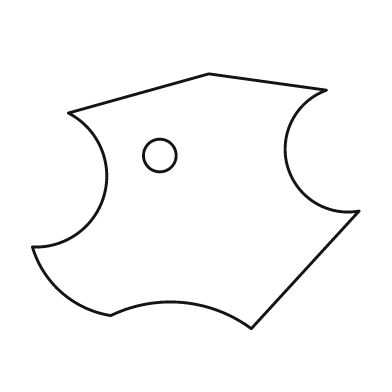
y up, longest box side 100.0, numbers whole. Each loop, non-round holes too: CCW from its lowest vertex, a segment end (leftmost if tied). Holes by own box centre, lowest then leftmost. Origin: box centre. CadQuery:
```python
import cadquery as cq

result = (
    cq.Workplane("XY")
    .moveTo(17.0, -39.0)
    .lineTo(50.0, -3.0)
    .threePointArc((28.0, 11.0), (40.0, 34.0))
    .lineTo(4.0, 39.0)
    .lineTo(-39.0, 27.0)
    .threePointArc((-28.0, 2.0), (-50.0, -14.0))
    .threePointArc((-41.0, -28.0), (-26.0, -35.0))
    .threePointArc((-4.0, -31.0), (17.0, -39.0))
    .close()
    .moveTo(-11.0, 14.0)
    .circle(5.0)
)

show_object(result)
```